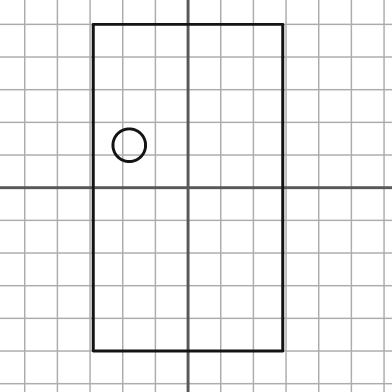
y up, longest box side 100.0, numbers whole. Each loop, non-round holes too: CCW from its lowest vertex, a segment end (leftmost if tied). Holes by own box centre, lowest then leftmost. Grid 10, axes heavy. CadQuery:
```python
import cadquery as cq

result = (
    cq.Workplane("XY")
    .moveTo(-29.0, -50.0)
    .lineTo(29.0, -50.0)
    .lineTo(29.0, 50.0)
    .lineTo(-29.0, 50.0)
    .close()
    .moveTo(-18.0, 13.0)
    .circle(5.0)
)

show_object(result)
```